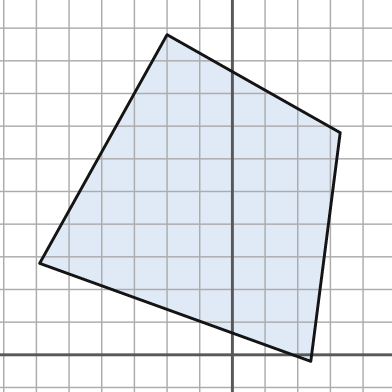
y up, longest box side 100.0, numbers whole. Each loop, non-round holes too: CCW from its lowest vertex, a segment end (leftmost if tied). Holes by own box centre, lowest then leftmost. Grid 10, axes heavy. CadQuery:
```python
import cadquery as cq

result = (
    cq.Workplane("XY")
    .moveTo(24.0, -2.0)
    .lineTo(33.0, 68.0)
    .lineTo(-20.0, 98.0)
    .lineTo(-59.0, 28.0)
    .close()
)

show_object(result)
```